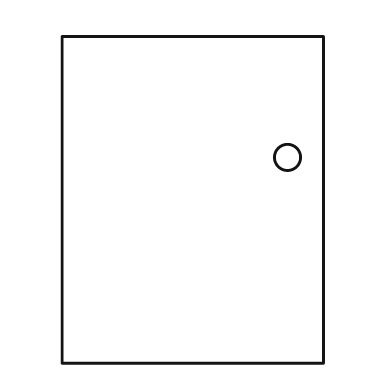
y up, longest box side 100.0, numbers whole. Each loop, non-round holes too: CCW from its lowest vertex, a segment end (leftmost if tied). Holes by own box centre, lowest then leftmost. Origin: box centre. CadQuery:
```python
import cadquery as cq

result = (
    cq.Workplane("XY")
    .moveTo(-40.0, -50.0)
    .lineTo(40.0, -50.0)
    .lineTo(40.0, 50.0)
    .lineTo(-40.0, 50.0)
    .close()
    .moveTo(29.0, 13.0)
    .circle(4.0)
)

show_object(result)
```